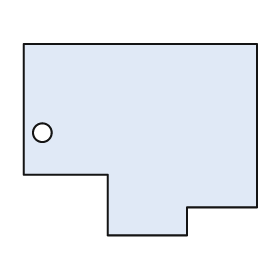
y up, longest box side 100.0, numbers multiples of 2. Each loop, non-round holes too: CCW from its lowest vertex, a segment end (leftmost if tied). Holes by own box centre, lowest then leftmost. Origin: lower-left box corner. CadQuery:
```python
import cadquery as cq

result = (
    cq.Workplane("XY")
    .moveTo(36.0, 0.0)
    .lineTo(70.0, 0.0)
    .lineTo(70.0, 12.0)
    .lineTo(100.0, 12.0)
    .lineTo(100.0, 82.0)
    .lineTo(0.0, 82.0)
    .lineTo(0.0, 26.0)
    .lineTo(36.0, 26.0)
    .close()
    .moveTo(8.0, 44.0)
    .circle(4.0)
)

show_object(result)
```